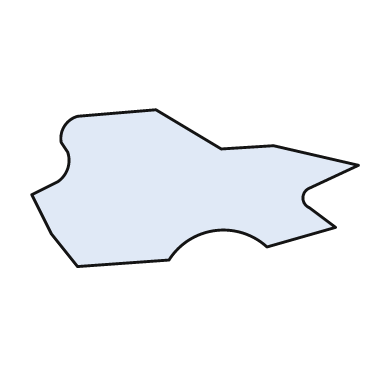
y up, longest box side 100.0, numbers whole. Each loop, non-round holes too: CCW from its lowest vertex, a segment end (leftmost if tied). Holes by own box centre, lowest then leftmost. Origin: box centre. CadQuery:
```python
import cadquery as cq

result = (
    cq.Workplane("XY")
    .moveTo(-36.0, -24.0)
    .lineTo(-8.0, -22.0)
    .threePointArc((6.0, -13.0), (22.0, -18.0))
    .lineTo(43.0, -12.0)
    .lineTo(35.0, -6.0)
    .threePointArc((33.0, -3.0), (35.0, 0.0))
    .lineTo(50.0, 7.0)
    .lineTo(24.0, 13.0)
    .lineTo(8.0, 12.0)
    .lineTo(-12.0, 24.0)
    .lineTo(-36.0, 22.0)
    .threePointArc((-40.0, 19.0), (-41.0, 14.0))
    .lineTo(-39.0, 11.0)
    .threePointArc((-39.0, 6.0), (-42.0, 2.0))
    .lineTo(-50.0, -2.0)
    .lineTo(-44.0, -14.0)
    .close()
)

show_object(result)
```